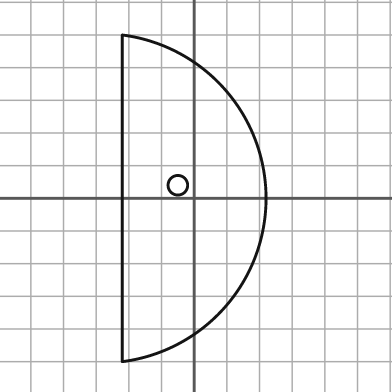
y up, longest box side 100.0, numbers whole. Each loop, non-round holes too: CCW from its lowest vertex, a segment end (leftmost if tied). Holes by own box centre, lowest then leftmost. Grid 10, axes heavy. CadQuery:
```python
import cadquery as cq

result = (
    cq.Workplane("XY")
    .moveTo(-22.0, -50.0)
    .threePointArc((22.0, 0.0), (-22.0, 50.0))
    .close()
    .moveTo(-5.0, 4.0)
    .circle(3.0)
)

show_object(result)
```